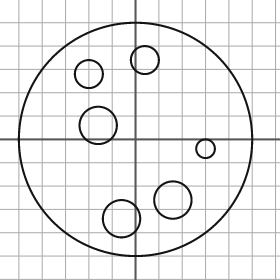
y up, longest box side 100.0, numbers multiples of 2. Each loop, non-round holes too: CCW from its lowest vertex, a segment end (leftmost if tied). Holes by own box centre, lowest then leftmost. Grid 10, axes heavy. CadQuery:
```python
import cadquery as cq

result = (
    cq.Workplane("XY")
    .moveTo(0.0, 0.0)
    .circle(50.0)
    .moveTo(-6.0, -34.0)
    .circle(8.0)
    .moveTo(16.0, -26.0)
    .circle(8.0)
    .moveTo(30.0, -4.0)
    .circle(4.0)
    .moveTo(-16.0, 6.0)
    .circle(8.0)
    .moveTo(-20.0, 28.0)
    .circle(6.0)
    .moveTo(4.0, 34.0)
    .circle(6.0)
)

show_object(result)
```